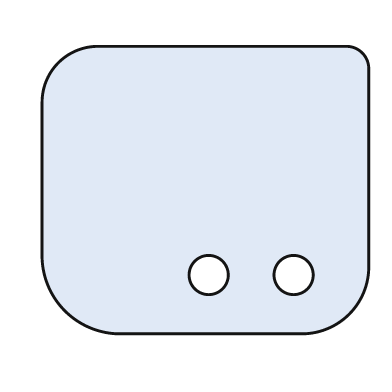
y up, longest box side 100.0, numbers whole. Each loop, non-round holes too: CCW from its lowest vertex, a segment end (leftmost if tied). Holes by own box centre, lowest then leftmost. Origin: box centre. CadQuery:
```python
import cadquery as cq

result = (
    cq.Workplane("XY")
    .moveTo(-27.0, -44.0)
    .lineTo(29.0, -44.0)
    .threePointArc((44.0, -38.0), (50.0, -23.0))
    .lineTo(50.0, 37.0)
    .threePointArc((48.0, 42.0), (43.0, 44.0))
    .lineTo(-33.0, 44.0)
    .threePointArc((-45.0, 39.0), (-50.0, 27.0))
    .lineTo(-50.0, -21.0)
    .threePointArc((-43.0, -37.0), (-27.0, -44.0))
    .close()
    .moveTo(1.0, -26.0)
    .circle(6.0)
    .moveTo(27.0, -26.0)
    .circle(6.0)
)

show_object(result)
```